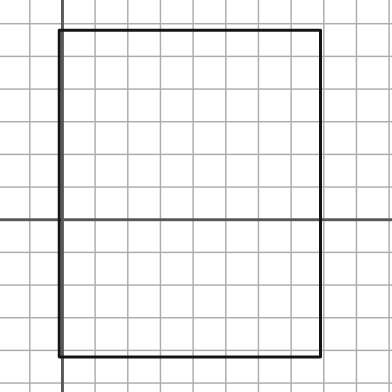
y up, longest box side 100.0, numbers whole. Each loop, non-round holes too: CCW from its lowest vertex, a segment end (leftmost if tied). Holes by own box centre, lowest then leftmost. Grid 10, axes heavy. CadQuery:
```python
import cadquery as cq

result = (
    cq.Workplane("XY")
    .moveTo(-1.0, -42.0)
    .lineTo(79.0, -42.0)
    .lineTo(79.0, 58.0)
    .lineTo(-1.0, 58.0)
    .close()
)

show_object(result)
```